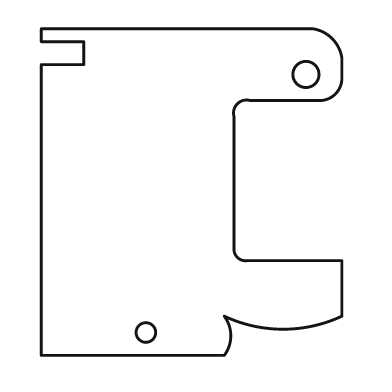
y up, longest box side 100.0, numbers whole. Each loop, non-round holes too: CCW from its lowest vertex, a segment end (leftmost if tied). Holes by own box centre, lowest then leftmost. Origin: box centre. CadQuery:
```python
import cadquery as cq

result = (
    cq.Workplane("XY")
    .moveTo(-46.0, -50.0)
    .lineTo(10.0, -50.0)
    .threePointArc((12.0, -44.0), (10.0, -38.0))
    .threePointArc((28.0, -42.0), (46.0, -38.0))
    .lineTo(46.0, -21.0)
    .lineTo(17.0, -21.0)
    .threePointArc((14.0, -20.0), (13.0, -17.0))
    .lineTo(13.0, 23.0)
    .threePointArc((14.0, 27.0), (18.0, 28.0))
    .lineTo(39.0, 28.0)
    .threePointArc((44.0, 30.0), (46.0, 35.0))
    .lineTo(46.0, 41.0)
    .threePointArc((43.0, 47.0), (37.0, 50.0))
    .lineTo(-46.0, 50.0)
    .lineTo(-46.0, 46.0)
    .lineTo(-33.0, 46.0)
    .lineTo(-33.0, 39.0)
    .lineTo(-46.0, 39.0)
    .close()
    .moveTo(-14.0, -43.0)
    .circle(3.0)
    .moveTo(35.0, 36.0)
    .circle(4.0)
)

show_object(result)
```